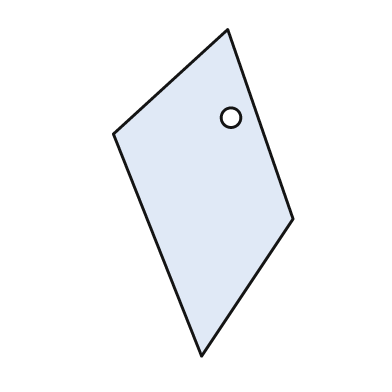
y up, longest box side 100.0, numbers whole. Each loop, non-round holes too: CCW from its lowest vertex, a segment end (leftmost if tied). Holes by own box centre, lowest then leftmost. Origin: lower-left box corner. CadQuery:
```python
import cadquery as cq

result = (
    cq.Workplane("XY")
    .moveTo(27.0, 0.0)
    .lineTo(55.0, 42.0)
    .lineTo(35.0, 100.0)
    .lineTo(0.0, 68.0)
    .close()
    .moveTo(36.0, 73.0)
    .circle(3.0)
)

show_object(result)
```